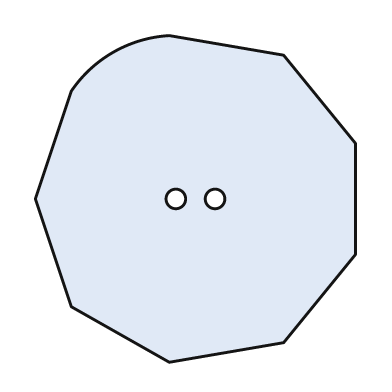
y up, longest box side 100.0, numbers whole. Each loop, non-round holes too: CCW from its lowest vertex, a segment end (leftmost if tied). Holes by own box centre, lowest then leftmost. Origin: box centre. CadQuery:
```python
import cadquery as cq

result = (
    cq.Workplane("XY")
    .moveTo(-8.0, -50.0)
    .lineTo(27.0, -44.0)
    .lineTo(49.0, -17.0)
    .lineTo(49.0, 17.0)
    .lineTo(27.0, 44.0)
    .lineTo(-8.0, 50.0)
    .threePointArc((-25.0, 45.0), (-38.0, 33.0))
    .lineTo(-49.0, 0.0)
    .lineTo(-38.0, -33.0)
    .close()
    .moveTo(-6.0, 0.0)
    .circle(3.0)
    .moveTo(6.0, 0.0)
    .circle(3.0)
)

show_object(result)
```